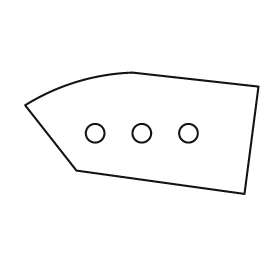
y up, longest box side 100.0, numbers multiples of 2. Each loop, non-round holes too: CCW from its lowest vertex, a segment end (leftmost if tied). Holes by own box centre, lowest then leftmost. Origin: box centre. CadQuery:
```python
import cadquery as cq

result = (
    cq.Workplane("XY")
    .moveTo(44.0, -26.0)
    .lineTo(50.0, 20.0)
    .lineTo(-4.0, 26.0)
    .threePointArc((-28.0, 22.0), (-50.0, 12.0))
    .lineTo(-28.0, -16.0)
    .close()
    .moveTo(-20.0, 0.0)
    .circle(4.0)
    .moveTo(0.0, 0.0)
    .circle(4.0)
    .moveTo(20.0, 0.0)
    .circle(4.0)
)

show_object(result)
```